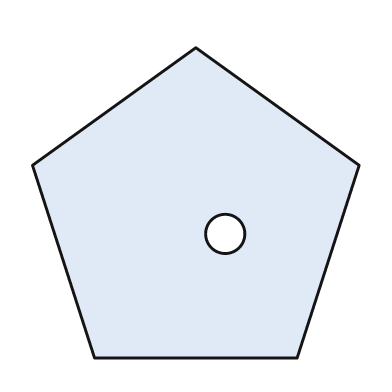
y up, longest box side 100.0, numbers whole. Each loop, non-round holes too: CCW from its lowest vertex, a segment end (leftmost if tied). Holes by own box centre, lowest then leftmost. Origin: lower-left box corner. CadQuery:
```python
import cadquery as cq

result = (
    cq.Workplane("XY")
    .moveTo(19.0, 0.0)
    .lineTo(81.0, 0.0)
    .lineTo(100.0, 59.0)
    .lineTo(50.0, 95.0)
    .lineTo(0.0, 59.0)
    .close()
    .moveTo(59.0, 38.0)
    .circle(6.0)
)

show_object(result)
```